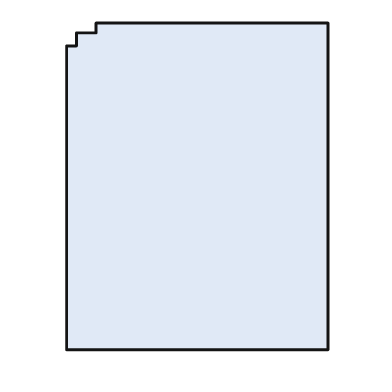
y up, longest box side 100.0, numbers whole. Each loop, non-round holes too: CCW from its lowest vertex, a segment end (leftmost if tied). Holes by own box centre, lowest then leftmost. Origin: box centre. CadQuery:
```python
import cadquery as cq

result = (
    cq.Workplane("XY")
    .moveTo(-40.0, -50.0)
    .lineTo(40.0, -50.0)
    .lineTo(40.0, 50.0)
    .lineTo(-31.0, 50.0)
    .lineTo(-31.0, 47.0)
    .lineTo(-37.0, 47.0)
    .lineTo(-37.0, 43.0)
    .lineTo(-40.0, 43.0)
    .close()
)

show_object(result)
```